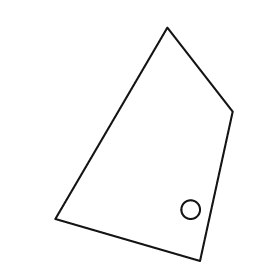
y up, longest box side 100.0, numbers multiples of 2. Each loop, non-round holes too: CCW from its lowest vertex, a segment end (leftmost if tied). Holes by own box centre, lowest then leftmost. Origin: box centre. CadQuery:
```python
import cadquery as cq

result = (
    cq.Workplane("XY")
    .moveTo(24.0, -50.0)
    .lineTo(38.0, 14.0)
    .lineTo(10.0, 50.0)
    .lineTo(-38.0, -32.0)
    .close()
    .moveTo(20.0, -28.0)
    .circle(4.0)
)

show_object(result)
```